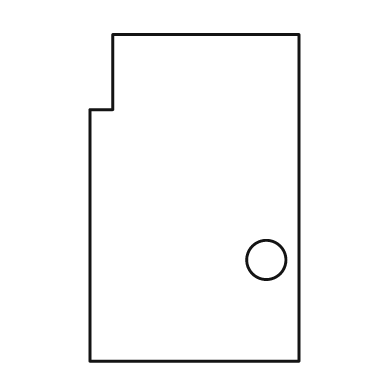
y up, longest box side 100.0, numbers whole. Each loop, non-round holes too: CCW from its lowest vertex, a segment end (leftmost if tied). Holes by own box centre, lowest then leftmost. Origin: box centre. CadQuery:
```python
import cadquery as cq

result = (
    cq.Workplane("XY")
    .moveTo(-32.0, -50.0)
    .lineTo(32.0, -50.0)
    .lineTo(32.0, 50.0)
    .lineTo(-25.0, 50.0)
    .lineTo(-25.0, 27.0)
    .lineTo(-32.0, 27.0)
    .close()
    .moveTo(22.0, -19.0)
    .circle(6.0)
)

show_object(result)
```